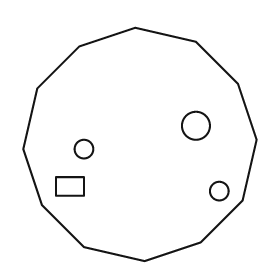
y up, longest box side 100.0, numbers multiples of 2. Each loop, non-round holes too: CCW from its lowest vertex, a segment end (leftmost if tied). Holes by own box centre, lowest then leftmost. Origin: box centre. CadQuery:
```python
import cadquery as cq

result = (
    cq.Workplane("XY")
    .moveTo(2.0, -50.0)
    .lineTo(26.0, -42.0)
    .lineTo(44.0, -24.0)
    .lineTo(50.0, 2.0)
    .lineTo(42.0, 26.0)
    .lineTo(24.0, 44.0)
    .lineTo(-2.0, 50.0)
    .lineTo(-26.0, 42.0)
    .lineTo(-44.0, 24.0)
    .lineTo(-50.0, -2.0)
    .lineTo(-42.0, -26.0)
    .lineTo(-24.0, -44.0)
    .close()
    .moveTo(34.0, -20.0)
    .circle(4.0)
    .moveTo(-36.0, -22.0)
    .lineTo(-24.0, -22.0)
    .lineTo(-24.0, -14.0)
    .lineTo(-36.0, -14.0)
    .close()
    .moveTo(-24.0, -2.0)
    .circle(4.0)
    .moveTo(24.0, 8.0)
    .circle(6.0)
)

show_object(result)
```